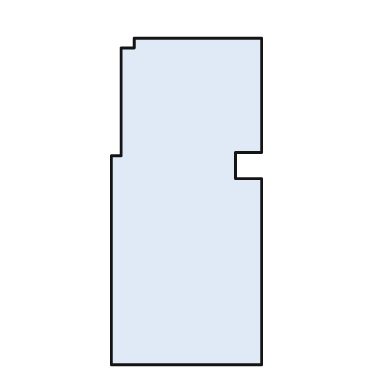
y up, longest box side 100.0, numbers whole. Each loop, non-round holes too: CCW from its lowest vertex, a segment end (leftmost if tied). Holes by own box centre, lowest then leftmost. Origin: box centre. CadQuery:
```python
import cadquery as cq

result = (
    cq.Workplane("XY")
    .moveTo(-23.0, -50.0)
    .lineTo(23.0, -50.0)
    .lineTo(23.0, 7.0)
    .lineTo(15.0, 7.0)
    .lineTo(15.0, 15.0)
    .lineTo(23.0, 15.0)
    .lineTo(23.0, 50.0)
    .lineTo(-16.0, 50.0)
    .lineTo(-16.0, 47.0)
    .lineTo(-20.0, 47.0)
    .lineTo(-20.0, 14.0)
    .lineTo(-23.0, 14.0)
    .close()
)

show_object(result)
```